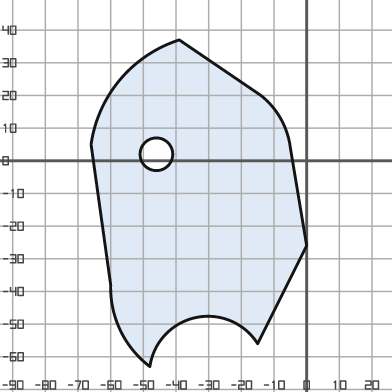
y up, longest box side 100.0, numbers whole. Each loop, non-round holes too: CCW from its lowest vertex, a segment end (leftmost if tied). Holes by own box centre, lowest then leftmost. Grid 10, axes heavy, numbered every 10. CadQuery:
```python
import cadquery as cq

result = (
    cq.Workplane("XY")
    .moveTo(-48.0, -63.0)
    .threePointArc((-34.0, -48.0), (-15.0, -56.0))
    .lineTo(0.0, -26.0)
    .lineTo(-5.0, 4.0)
    .threePointArc((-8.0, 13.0), (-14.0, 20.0))
    .lineTo(-39.0, 37.0)
    .threePointArc((-57.0, 25.0), (-66.0, 5.0))
    .lineTo(-60.0, -38.0)
    .threePointArc((-57.0, -52.0), (-48.0, -63.0))
    .close()
    .moveTo(-46.0, 2.0)
    .circle(5.0)
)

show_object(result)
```